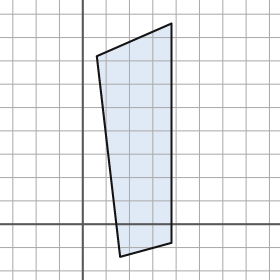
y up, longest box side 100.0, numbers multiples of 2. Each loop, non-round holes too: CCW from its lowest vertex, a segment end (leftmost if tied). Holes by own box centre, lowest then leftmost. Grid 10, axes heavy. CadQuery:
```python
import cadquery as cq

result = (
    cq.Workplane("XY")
    .moveTo(16.0, -14.0)
    .lineTo(38.0, -8.0)
    .lineTo(38.0, 86.0)
    .lineTo(6.0, 72.0)
    .close()
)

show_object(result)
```